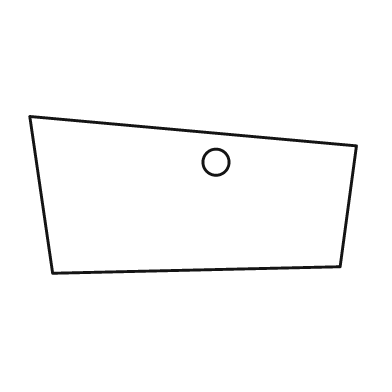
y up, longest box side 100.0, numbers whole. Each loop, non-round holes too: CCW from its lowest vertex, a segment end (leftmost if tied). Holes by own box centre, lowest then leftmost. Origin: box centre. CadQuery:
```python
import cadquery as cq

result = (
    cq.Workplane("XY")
    .moveTo(-43.0, -24.0)
    .lineTo(45.0, -22.0)
    .lineTo(50.0, 15.0)
    .lineTo(-50.0, 24.0)
    .close()
    .moveTo(7.0, 10.0)
    .circle(4.0)
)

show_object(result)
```